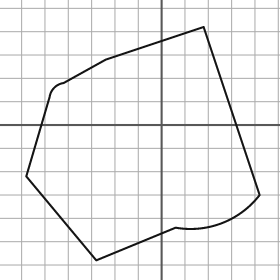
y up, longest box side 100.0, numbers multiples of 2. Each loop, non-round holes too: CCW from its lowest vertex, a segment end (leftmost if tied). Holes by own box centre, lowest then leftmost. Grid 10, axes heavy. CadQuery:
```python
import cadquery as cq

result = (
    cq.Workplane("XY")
    .moveTo(-28.0, -58.0)
    .lineTo(6.0, -44.0)
    .threePointArc((26.0, -42.0), (42.0, -30.0))
    .lineTo(18.0, 42.0)
    .lineTo(-24.0, 28.0)
    .lineTo(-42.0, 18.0)
    .threePointArc((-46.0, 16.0), (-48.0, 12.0))
    .lineTo(-58.0, -22.0)
    .close()
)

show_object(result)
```